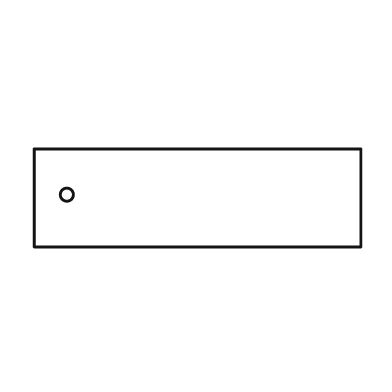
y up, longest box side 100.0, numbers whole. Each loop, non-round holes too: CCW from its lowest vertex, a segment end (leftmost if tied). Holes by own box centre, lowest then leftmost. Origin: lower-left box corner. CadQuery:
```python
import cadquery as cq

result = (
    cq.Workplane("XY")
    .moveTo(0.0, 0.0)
    .lineTo(100.0, 0.0)
    .lineTo(100.0, 30.0)
    .lineTo(0.0, 30.0)
    .close()
    .moveTo(10.0, 16.0)
    .circle(2.0)
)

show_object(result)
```